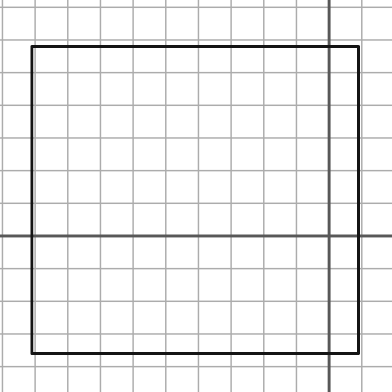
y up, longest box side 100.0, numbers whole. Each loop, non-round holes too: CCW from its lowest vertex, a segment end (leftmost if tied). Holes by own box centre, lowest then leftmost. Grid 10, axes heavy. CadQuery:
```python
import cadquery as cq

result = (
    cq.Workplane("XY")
    .moveTo(-91.0, -36.0)
    .lineTo(9.0, -36.0)
    .lineTo(9.0, 58.0)
    .lineTo(-91.0, 58.0)
    .close()
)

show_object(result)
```